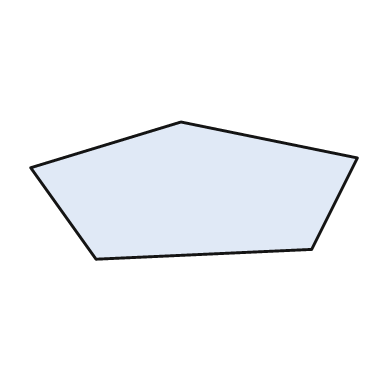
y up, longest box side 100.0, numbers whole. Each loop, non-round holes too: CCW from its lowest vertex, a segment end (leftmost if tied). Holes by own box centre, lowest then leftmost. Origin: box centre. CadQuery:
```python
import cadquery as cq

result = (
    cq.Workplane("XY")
    .moveTo(-30.0, -21.0)
    .lineTo(36.0, -18.0)
    .lineTo(50.0, 10.0)
    .lineTo(-4.0, 21.0)
    .lineTo(-50.0, 7.0)
    .close()
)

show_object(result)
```